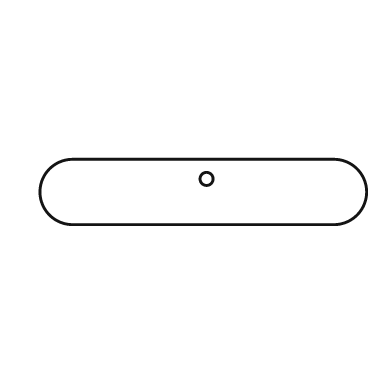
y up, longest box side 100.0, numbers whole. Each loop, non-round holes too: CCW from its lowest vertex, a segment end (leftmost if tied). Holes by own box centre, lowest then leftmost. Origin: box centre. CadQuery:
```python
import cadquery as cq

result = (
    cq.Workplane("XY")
    .moveTo(-40.0, -10.0)
    .lineTo(40.0, -10.0)
    .threePointArc((50.0, 0.0), (40.0, 10.0))
    .lineTo(-40.0, 10.0)
    .threePointArc((-50.0, 0.0), (-40.0, -10.0))
    .close()
    .moveTo(1.0, 4.0)
    .circle(2.0)
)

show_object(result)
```